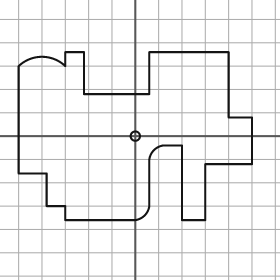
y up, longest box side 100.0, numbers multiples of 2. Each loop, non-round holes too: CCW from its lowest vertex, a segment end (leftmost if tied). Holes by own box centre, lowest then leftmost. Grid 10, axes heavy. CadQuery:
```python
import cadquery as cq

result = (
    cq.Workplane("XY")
    .moveTo(-30.0, -36.0)
    .lineTo(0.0, -36.0)
    .threePointArc((4.0, -34.0), (6.0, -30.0))
    .lineTo(6.0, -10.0)
    .threePointArc((8.0, -6.0), (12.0, -4.0))
    .lineTo(20.0, -4.0)
    .lineTo(20.0, -36.0)
    .lineTo(30.0, -36.0)
    .lineTo(30.0, -12.0)
    .lineTo(50.0, -12.0)
    .lineTo(50.0, 8.0)
    .lineTo(40.0, 8.0)
    .lineTo(40.0, 36.0)
    .lineTo(6.0, 36.0)
    .lineTo(6.0, 18.0)
    .lineTo(-22.0, 18.0)
    .lineTo(-22.0, 36.0)
    .lineTo(-30.0, 36.0)
    .lineTo(-30.0, 30.0)
    .threePointArc((-40.0, 34.0), (-50.0, 30.0))
    .lineTo(-50.0, -16.0)
    .lineTo(-38.0, -16.0)
    .lineTo(-38.0, -30.0)
    .lineTo(-30.0, -30.0)
    .close()
    .moveTo(0.0, 0.0)
    .circle(2.0)
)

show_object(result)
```